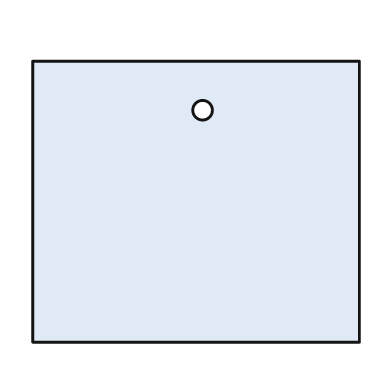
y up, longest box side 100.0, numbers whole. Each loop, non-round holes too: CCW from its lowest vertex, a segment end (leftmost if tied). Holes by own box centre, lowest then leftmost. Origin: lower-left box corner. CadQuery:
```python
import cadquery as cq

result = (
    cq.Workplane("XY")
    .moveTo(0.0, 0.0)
    .lineTo(100.0, 0.0)
    .lineTo(100.0, 86.0)
    .lineTo(0.0, 86.0)
    .close()
    .moveTo(52.0, 71.0)
    .circle(3.0)
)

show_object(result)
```